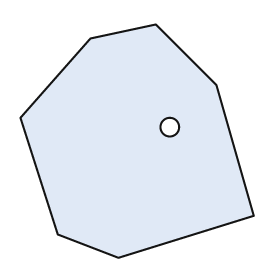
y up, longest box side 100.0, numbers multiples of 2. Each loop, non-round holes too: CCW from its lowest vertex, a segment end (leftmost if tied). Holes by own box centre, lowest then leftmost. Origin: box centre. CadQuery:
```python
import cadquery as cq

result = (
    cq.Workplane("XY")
    .moveTo(-8.0, -50.0)
    .lineTo(50.0, -32.0)
    .lineTo(34.0, 24.0)
    .lineTo(8.0, 50.0)
    .lineTo(-20.0, 44.0)
    .lineTo(-50.0, 10.0)
    .lineTo(-34.0, -40.0)
    .close()
    .moveTo(14.0, 6.0)
    .circle(4.0)
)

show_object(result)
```